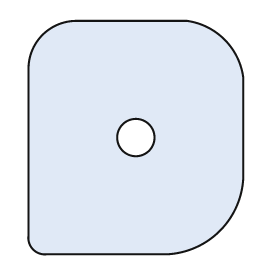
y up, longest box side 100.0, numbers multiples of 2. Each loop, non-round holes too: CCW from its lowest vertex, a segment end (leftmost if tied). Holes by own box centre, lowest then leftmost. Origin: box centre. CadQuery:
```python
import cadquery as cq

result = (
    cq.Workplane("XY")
    .moveTo(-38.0, -50.0)
    .lineTo(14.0, -50.0)
    .threePointArc((36.0, -40.0), (46.0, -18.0))
    .lineTo(46.0, 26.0)
    .threePointArc((38.0, 42.0), (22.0, 50.0))
    .lineTo(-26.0, 50.0)
    .threePointArc((-40.0, 44.0), (-46.0, 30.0))
    .lineTo(-46.0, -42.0)
    .threePointArc((-44.0, -48.0), (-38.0, -50.0))
    .close()
    .moveTo(0.0, 0.0)
    .circle(8.0)
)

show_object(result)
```